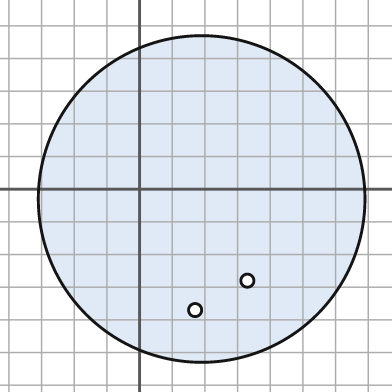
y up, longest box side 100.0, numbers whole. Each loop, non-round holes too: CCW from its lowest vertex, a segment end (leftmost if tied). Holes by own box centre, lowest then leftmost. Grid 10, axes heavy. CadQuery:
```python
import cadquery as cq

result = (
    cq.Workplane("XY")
    .moveTo(19.0, -3.0)
    .circle(50.0)
    .moveTo(17.0, -37.0)
    .circle(2.0)
    .moveTo(33.0, -28.0)
    .circle(2.0)
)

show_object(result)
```